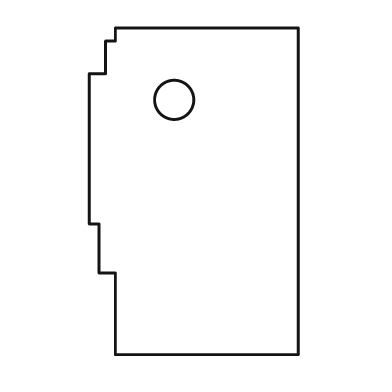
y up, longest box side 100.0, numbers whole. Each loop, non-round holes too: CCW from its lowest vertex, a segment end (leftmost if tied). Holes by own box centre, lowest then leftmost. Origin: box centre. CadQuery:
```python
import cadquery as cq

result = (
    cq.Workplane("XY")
    .moveTo(-24.0, -50.0)
    .lineTo(32.0, -50.0)
    .lineTo(32.0, 50.0)
    .lineTo(-24.0, 50.0)
    .lineTo(-24.0, 46.0)
    .lineTo(-27.0, 46.0)
    .lineTo(-27.0, 36.0)
    .lineTo(-32.0, 36.0)
    .lineTo(-32.0, -10.0)
    .lineTo(-29.0, -10.0)
    .lineTo(-29.0, -25.0)
    .lineTo(-24.0, -25.0)
    .close()
    .moveTo(-6.0, 28.0)
    .circle(6.0)
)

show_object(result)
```